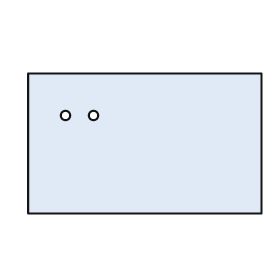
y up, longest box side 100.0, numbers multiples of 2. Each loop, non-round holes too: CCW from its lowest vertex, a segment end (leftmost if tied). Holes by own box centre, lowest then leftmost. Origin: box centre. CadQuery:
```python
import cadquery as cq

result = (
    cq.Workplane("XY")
    .moveTo(-50.0, -30.0)
    .lineTo(50.0, -30.0)
    .lineTo(50.0, 30.0)
    .lineTo(-50.0, 30.0)
    .close()
    .moveTo(-34.0, 12.0)
    .circle(2.0)
    .moveTo(-22.0, 12.0)
    .circle(2.0)
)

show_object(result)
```